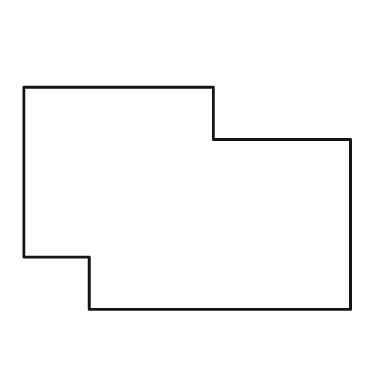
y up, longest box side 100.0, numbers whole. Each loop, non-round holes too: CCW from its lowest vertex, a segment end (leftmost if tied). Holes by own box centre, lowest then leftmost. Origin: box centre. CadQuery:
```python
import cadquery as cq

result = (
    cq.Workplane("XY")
    .moveTo(-30.0, -34.0)
    .lineTo(50.0, -34.0)
    .lineTo(50.0, 18.0)
    .lineTo(8.0, 18.0)
    .lineTo(8.0, 34.0)
    .lineTo(-50.0, 34.0)
    .lineTo(-50.0, -18.0)
    .lineTo(-30.0, -18.0)
    .close()
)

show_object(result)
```